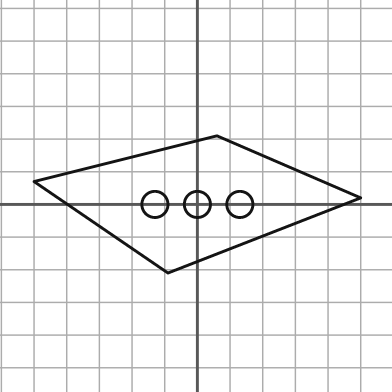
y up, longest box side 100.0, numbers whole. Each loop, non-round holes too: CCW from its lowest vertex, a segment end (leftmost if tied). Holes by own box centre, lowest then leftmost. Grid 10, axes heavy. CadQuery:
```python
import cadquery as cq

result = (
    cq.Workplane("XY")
    .moveTo(-9.0, -21.0)
    .lineTo(50.0, 2.0)
    .lineTo(6.0, 21.0)
    .lineTo(-50.0, 7.0)
    .close()
    .moveTo(-13.0, 0.0)
    .circle(4.0)
    .moveTo(0.0, 0.0)
    .circle(4.0)
    .moveTo(13.0, 0.0)
    .circle(4.0)
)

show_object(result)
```